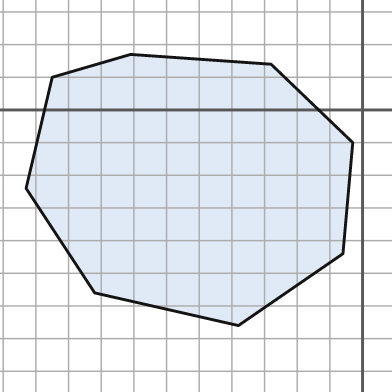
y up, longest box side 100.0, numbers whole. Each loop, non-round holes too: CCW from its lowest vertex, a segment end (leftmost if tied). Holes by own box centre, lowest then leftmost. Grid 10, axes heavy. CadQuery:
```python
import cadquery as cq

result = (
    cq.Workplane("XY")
    .moveTo(-38.0, -66.0)
    .lineTo(-6.0, -44.0)
    .lineTo(-3.0, -10.0)
    .lineTo(-28.0, 14.0)
    .lineTo(-71.0, 17.0)
    .lineTo(-95.0, 10.0)
    .lineTo(-103.0, -24.0)
    .lineTo(-82.0, -56.0)
    .close()
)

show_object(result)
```